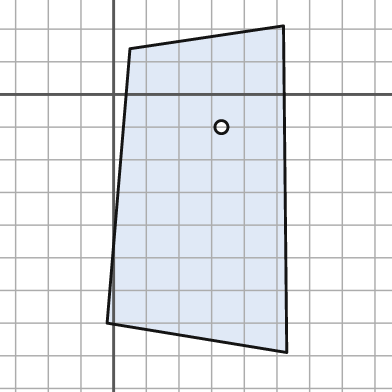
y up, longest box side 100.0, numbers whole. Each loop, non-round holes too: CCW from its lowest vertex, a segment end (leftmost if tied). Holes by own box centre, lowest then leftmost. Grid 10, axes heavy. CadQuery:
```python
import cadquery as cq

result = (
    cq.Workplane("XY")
    .moveTo(53.0, -79.0)
    .lineTo(52.0, 21.0)
    .lineTo(5.0, 14.0)
    .lineTo(-2.0, -70.0)
    .close()
    .moveTo(33.0, -10.0)
    .circle(2.0)
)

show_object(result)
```